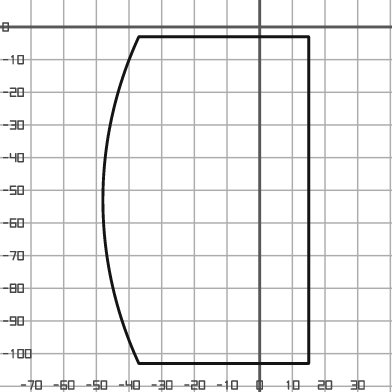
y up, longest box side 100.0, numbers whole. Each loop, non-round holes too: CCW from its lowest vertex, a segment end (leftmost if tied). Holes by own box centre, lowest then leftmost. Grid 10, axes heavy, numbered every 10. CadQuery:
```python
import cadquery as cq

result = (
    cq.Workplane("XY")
    .moveTo(-37.0, -103.0)
    .lineTo(15.0, -103.0)
    .lineTo(15.0, -3.0)
    .lineTo(-37.0, -3.0)
    .threePointArc((-48.0, -53.0), (-37.0, -103.0))
    .close()
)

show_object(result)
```